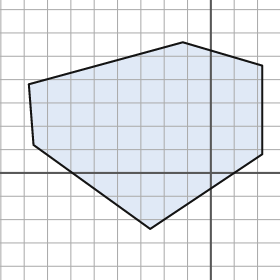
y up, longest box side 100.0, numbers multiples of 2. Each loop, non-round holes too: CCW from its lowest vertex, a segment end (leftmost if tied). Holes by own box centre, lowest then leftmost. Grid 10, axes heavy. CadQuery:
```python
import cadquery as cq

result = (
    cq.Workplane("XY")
    .moveTo(-26.0, -24.0)
    .lineTo(22.0, 8.0)
    .lineTo(22.0, 46.0)
    .lineTo(-12.0, 56.0)
    .lineTo(-78.0, 38.0)
    .lineTo(-76.0, 12.0)
    .close()
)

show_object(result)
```